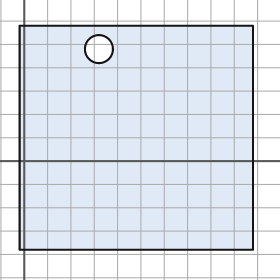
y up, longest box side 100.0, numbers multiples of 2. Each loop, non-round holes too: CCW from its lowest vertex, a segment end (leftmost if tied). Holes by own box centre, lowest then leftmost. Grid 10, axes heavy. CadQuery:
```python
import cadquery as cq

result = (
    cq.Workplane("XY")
    .moveTo(-2.0, -38.0)
    .lineTo(98.0, -38.0)
    .lineTo(98.0, 58.0)
    .lineTo(-2.0, 58.0)
    .close()
    .moveTo(32.0, 48.0)
    .circle(6.0)
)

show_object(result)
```